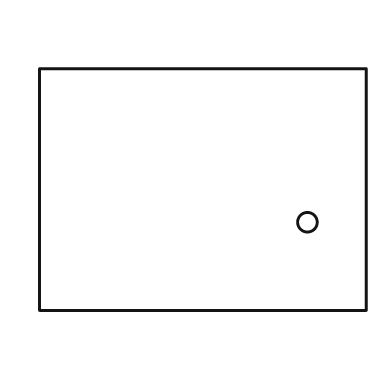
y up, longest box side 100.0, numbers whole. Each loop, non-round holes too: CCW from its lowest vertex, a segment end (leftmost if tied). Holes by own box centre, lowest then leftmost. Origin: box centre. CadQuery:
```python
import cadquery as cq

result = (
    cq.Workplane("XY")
    .moveTo(-50.0, -37.0)
    .lineTo(50.0, -37.0)
    .lineTo(50.0, 37.0)
    .lineTo(-50.0, 37.0)
    .close()
    .moveTo(32.0, -10.0)
    .circle(3.0)
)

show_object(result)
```